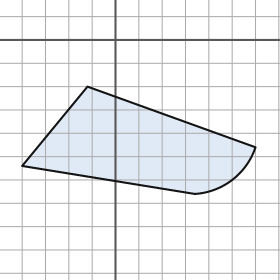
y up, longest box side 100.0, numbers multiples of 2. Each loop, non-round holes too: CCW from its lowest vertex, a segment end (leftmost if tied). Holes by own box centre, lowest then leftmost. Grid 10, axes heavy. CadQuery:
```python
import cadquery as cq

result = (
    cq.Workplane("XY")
    .moveTo(34.0, -66.0)
    .threePointArc((50.0, -60.0), (60.0, -46.0))
    .lineTo(-12.0, -20.0)
    .lineTo(-40.0, -54.0)
    .close()
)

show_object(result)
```